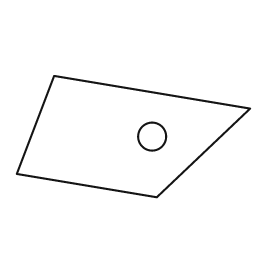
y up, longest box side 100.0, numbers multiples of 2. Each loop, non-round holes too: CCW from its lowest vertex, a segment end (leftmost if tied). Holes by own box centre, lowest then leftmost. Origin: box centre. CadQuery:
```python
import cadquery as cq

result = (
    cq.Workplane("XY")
    .moveTo(10.0, -26.0)
    .lineTo(50.0, 12.0)
    .lineTo(-34.0, 26.0)
    .lineTo(-50.0, -16.0)
    .close()
    .moveTo(8.0, 0.0)
    .circle(6.0)
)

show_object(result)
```